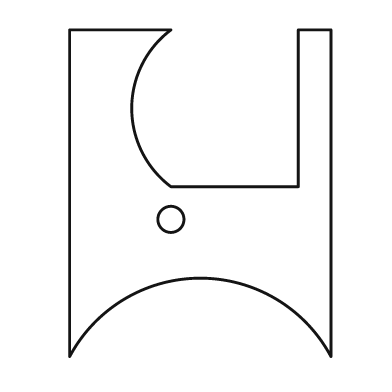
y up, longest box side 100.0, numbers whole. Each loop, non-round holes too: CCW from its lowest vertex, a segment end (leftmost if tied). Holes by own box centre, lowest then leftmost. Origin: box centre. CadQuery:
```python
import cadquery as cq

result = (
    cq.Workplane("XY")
    .moveTo(-40.0, -50.0)
    .threePointArc((0.0, -26.0), (40.0, -50.0))
    .lineTo(40.0, 50.0)
    .lineTo(30.0, 50.0)
    .lineTo(30.0, 2.0)
    .lineTo(-9.0, 2.0)
    .threePointArc((-21.0, 26.0), (-9.0, 50.0))
    .lineTo(-40.0, 50.0)
    .close()
    .moveTo(-9.0, -8.0)
    .circle(4.0)
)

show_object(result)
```